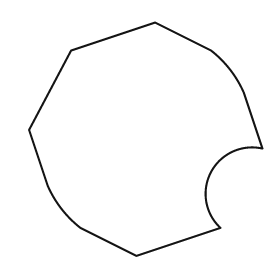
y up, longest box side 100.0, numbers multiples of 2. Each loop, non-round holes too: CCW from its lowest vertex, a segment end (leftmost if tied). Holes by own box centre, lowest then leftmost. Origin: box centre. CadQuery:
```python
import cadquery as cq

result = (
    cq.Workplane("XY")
    .moveTo(-4.0, -50.0)
    .lineTo(32.0, -38.0)
    .threePointArc((28.0, -14.0), (50.0, -4.0))
    .lineTo(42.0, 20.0)
    .threePointArc((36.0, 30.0), (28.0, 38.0))
    .lineTo(4.0, 50.0)
    .lineTo(-32.0, 38.0)
    .lineTo(-50.0, 4.0)
    .lineTo(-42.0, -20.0)
    .threePointArc((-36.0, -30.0), (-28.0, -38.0))
    .close()
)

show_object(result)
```